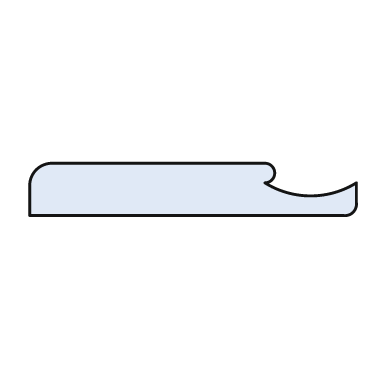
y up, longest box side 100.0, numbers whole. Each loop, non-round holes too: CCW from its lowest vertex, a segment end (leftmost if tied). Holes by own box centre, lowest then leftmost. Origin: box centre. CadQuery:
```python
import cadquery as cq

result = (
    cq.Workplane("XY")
    .moveTo(-50.0, -8.0)
    .lineTo(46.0, -8.0)
    .threePointArc((49.0, -7.0), (50.0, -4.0))
    .lineTo(50.0, 2.0)
    .threePointArc((36.0, -2.0), (22.0, 2.0))
    .threePointArc((25.0, 5.0), (22.0, 8.0))
    .lineTo(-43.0, 8.0)
    .threePointArc((-48.0, 6.0), (-50.0, 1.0))
    .close()
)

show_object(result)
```